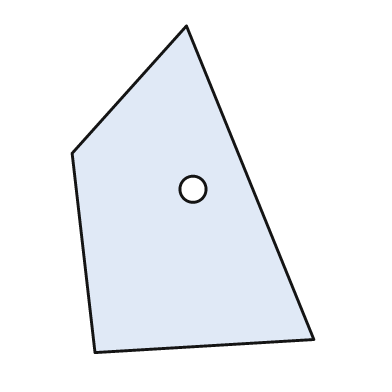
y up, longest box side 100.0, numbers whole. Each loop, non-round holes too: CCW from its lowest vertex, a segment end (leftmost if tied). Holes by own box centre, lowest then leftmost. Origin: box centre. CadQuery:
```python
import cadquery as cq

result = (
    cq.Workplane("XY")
    .moveTo(-30.0, -50.0)
    .lineTo(37.0, -46.0)
    .lineTo(-2.0, 50.0)
    .lineTo(-37.0, 11.0)
    .close()
    .moveTo(0.0, 0.0)
    .circle(4.0)
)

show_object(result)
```